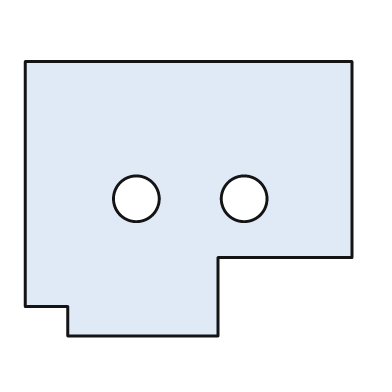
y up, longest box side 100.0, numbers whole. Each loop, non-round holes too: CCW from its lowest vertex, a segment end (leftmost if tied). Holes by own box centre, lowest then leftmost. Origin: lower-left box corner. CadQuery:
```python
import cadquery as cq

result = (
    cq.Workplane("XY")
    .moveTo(13.0, 0.0)
    .lineTo(59.0, 0.0)
    .lineTo(59.0, 24.0)
    .lineTo(100.0, 24.0)
    .lineTo(100.0, 84.0)
    .lineTo(0.0, 84.0)
    .lineTo(0.0, 9.0)
    .lineTo(13.0, 9.0)
    .close()
    .moveTo(34.0, 42.0)
    .circle(7.0)
    .moveTo(67.0, 42.0)
    .circle(7.0)
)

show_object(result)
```